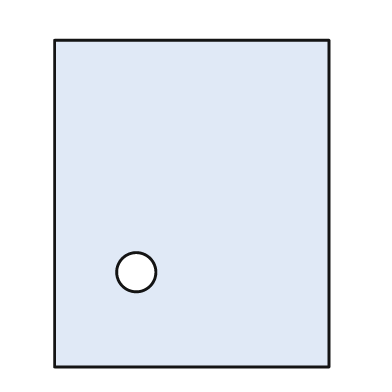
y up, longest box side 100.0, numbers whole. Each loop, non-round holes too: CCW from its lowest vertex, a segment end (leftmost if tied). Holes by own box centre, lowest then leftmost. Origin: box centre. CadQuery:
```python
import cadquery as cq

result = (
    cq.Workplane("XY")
    .moveTo(-42.0, -50.0)
    .lineTo(42.0, -50.0)
    .lineTo(42.0, 50.0)
    .lineTo(-42.0, 50.0)
    .close()
    .moveTo(-17.0, -21.0)
    .circle(6.0)
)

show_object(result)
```